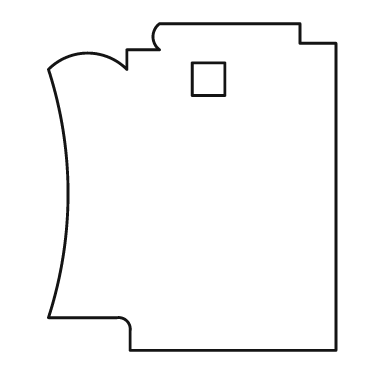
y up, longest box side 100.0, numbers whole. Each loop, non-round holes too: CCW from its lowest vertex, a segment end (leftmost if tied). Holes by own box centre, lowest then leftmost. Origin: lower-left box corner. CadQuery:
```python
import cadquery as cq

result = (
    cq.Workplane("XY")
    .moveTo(25.0, 0.0)
    .lineTo(88.0, 0.0)
    .lineTo(88.0, 94.0)
    .lineTo(77.0, 94.0)
    .lineTo(77.0, 100.0)
    .lineTo(34.0, 100.0)
    .threePointArc((32.0, 96.0), (34.0, 92.0))
    .lineTo(24.0, 92.0)
    .lineTo(24.0, 86.0)
    .threePointArc((12.0, 91.0), (0.0, 86.0))
    .threePointArc((6.0, 48.0), (0.0, 10.0))
    .lineTo(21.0, 10.0)
    .threePointArc((24.0, 9.0), (25.0, 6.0))
    .close()
    .moveTo(44.0, 78.0)
    .lineTo(54.0, 78.0)
    .lineTo(54.0, 88.0)
    .lineTo(44.0, 88.0)
    .close()
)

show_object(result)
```